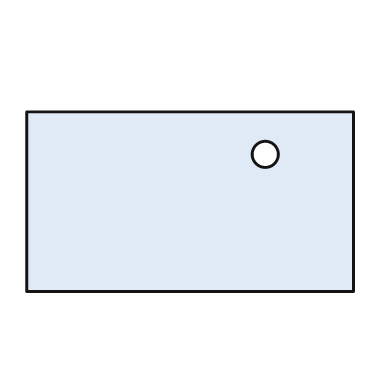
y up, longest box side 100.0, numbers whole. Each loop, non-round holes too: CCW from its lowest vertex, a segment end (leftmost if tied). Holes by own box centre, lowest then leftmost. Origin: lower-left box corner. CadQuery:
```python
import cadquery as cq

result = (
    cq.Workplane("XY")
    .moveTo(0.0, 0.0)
    .lineTo(100.0, 0.0)
    .lineTo(100.0, 55.0)
    .lineTo(0.0, 55.0)
    .close()
    .moveTo(73.0, 42.0)
    .circle(4.0)
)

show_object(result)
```